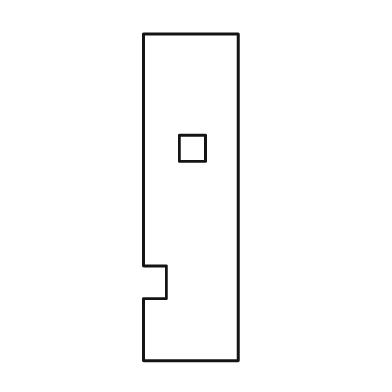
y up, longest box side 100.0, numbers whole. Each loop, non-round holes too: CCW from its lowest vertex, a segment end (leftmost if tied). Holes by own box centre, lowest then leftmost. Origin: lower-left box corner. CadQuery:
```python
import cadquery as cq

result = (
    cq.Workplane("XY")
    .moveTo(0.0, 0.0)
    .lineTo(29.0, 0.0)
    .lineTo(29.0, 100.0)
    .lineTo(0.0, 100.0)
    .lineTo(0.0, 29.0)
    .lineTo(7.0, 29.0)
    .lineTo(7.0, 19.0)
    .lineTo(0.0, 19.0)
    .close()
    .moveTo(11.0, 61.0)
    .lineTo(19.0, 61.0)
    .lineTo(19.0, 69.0)
    .lineTo(11.0, 69.0)
    .close()
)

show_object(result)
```